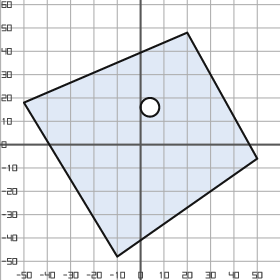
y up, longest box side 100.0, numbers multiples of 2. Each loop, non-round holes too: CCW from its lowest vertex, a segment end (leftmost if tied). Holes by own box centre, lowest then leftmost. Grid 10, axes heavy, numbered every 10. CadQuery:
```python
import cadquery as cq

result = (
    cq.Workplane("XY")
    .moveTo(-10.0, -48.0)
    .lineTo(50.0, -6.0)
    .lineTo(20.0, 48.0)
    .lineTo(-50.0, 18.0)
    .close()
    .moveTo(4.0, 16.0)
    .circle(4.0)
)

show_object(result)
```